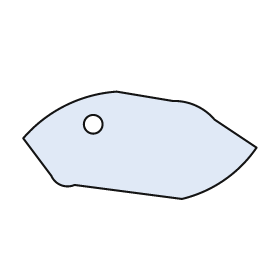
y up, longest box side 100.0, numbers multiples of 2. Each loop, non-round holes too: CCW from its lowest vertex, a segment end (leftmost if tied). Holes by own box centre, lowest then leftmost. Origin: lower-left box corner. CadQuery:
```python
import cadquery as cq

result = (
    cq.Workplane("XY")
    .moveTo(68.0, 0.0)
    .threePointArc((86.0, 8.0), (100.0, 22.0))
    .lineTo(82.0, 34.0)
    .threePointArc((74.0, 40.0), (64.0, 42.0))
    .lineTo(40.0, 46.0)
    .threePointArc((18.0, 40.0), (0.0, 26.0))
    .lineTo(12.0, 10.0)
    .threePointArc((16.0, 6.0), (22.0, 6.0))
    .close()
    .moveTo(30.0, 32.0)
    .circle(4.0)
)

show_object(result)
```